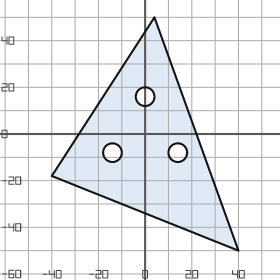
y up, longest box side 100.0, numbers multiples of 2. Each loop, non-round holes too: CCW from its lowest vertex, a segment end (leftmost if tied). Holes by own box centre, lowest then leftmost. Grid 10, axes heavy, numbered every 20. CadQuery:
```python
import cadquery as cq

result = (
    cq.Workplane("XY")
    .moveTo(40.0, -50.0)
    .lineTo(4.0, 50.0)
    .lineTo(-40.0, -18.0)
    .close()
    .moveTo(-14.0, -8.0)
    .circle(4.0)
    .moveTo(14.0, -8.0)
    .circle(4.0)
    .moveTo(0.0, 16.0)
    .circle(4.0)
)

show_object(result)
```